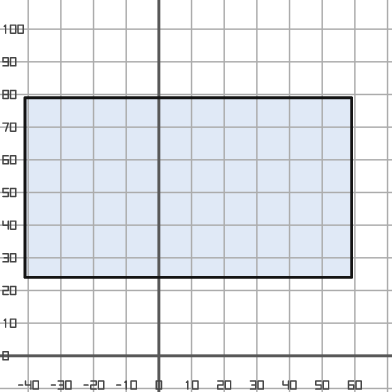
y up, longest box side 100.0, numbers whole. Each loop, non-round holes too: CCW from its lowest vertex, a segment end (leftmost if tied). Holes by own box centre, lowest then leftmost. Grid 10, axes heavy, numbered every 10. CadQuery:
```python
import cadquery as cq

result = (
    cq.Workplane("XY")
    .moveTo(-41.0, 24.0)
    .lineTo(59.0, 24.0)
    .lineTo(59.0, 79.0)
    .lineTo(-41.0, 79.0)
    .close()
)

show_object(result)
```